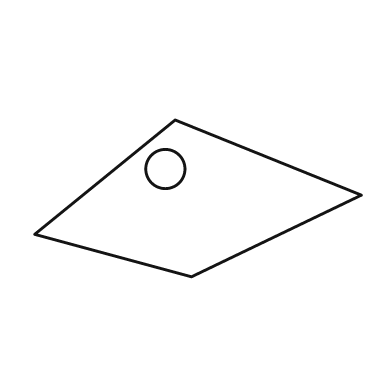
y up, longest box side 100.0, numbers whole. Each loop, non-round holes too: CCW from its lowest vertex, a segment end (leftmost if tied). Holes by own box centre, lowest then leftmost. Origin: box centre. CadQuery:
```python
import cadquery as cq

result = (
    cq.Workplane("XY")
    .moveTo(-2.0, -24.0)
    .lineTo(50.0, 1.0)
    .lineTo(-7.0, 24.0)
    .lineTo(-50.0, -11.0)
    .close()
    .moveTo(-10.0, 9.0)
    .circle(6.0)
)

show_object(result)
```